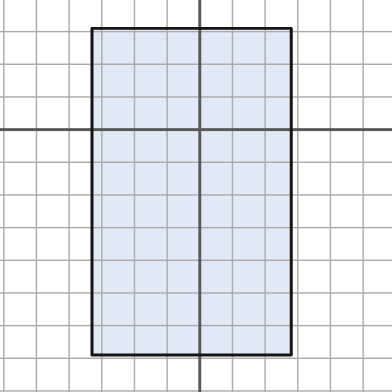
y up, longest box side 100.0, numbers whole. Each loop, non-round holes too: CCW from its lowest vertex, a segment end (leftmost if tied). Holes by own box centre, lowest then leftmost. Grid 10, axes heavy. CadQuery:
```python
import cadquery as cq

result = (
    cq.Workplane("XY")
    .moveTo(-33.0, -69.0)
    .lineTo(28.0, -69.0)
    .lineTo(28.0, 31.0)
    .lineTo(-33.0, 31.0)
    .close()
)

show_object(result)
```